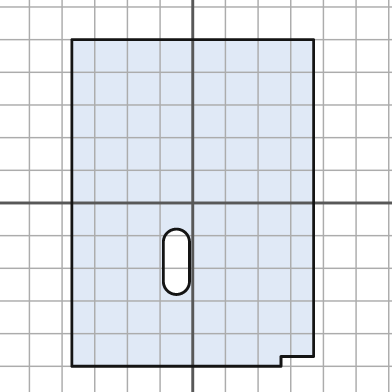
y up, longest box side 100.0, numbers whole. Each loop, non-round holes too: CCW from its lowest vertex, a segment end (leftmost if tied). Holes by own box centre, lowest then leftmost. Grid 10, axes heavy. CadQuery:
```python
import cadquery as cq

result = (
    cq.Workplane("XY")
    .moveTo(-37.0, -50.0)
    .lineTo(27.0, -50.0)
    .lineTo(27.0, -47.0)
    .lineTo(37.0, -47.0)
    .lineTo(37.0, 50.0)
    .lineTo(-37.0, 50.0)
    .close()
    .moveTo(-9.0, -24.0)
    .threePointArc((-5.0, -28.0), (-1.0, -24.0))
    .lineTo(-1.0, -12.0)
    .threePointArc((-5.0, -8.0), (-9.0, -12.0))
    .close()
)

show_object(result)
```